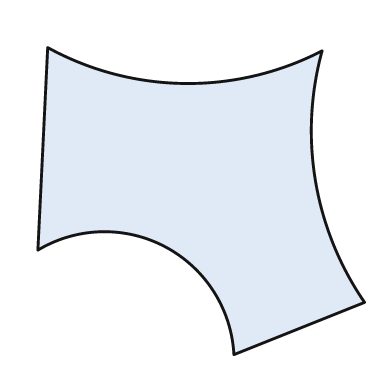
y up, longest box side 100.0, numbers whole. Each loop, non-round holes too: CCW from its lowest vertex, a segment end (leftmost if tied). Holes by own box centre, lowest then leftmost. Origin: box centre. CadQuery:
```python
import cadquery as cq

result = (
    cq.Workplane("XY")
    .moveTo(10.0, -47.0)
    .lineTo(50.0, -31.0)
    .threePointArc((35.0, 6.0), (37.0, 46.0))
    .threePointArc((-5.0, 36.0), (-47.0, 47.0))
    .lineTo(-50.0, -15.0)
    .threePointArc((-11.0, -14.0), (10.0, -47.0))
    .close()
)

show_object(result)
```